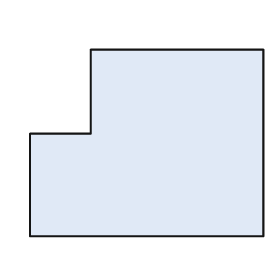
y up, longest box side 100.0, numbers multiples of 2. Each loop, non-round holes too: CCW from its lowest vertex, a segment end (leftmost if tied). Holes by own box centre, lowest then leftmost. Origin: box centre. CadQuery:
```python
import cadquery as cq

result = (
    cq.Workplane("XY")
    .moveTo(-50.0, -40.0)
    .lineTo(50.0, -40.0)
    .lineTo(50.0, 40.0)
    .lineTo(-24.0, 40.0)
    .lineTo(-24.0, 4.0)
    .lineTo(-50.0, 4.0)
    .close()
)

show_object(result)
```